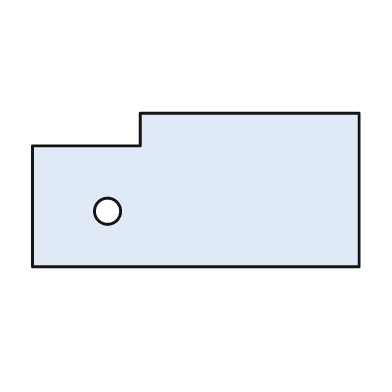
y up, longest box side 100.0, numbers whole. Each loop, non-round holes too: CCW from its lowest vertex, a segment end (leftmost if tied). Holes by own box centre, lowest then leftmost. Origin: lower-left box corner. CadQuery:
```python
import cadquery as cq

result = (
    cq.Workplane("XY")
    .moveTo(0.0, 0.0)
    .lineTo(100.0, 0.0)
    .lineTo(100.0, 47.0)
    .lineTo(33.0, 47.0)
    .lineTo(33.0, 37.0)
    .lineTo(0.0, 37.0)
    .close()
    .moveTo(23.0, 17.0)
    .circle(4.0)
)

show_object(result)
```